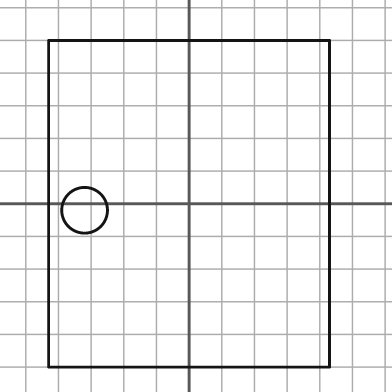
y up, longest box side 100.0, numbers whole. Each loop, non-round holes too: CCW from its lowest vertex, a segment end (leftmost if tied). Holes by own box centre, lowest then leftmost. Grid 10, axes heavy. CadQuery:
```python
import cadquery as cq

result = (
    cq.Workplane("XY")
    .moveTo(-43.0, -50.0)
    .lineTo(43.0, -50.0)
    .lineTo(43.0, 50.0)
    .lineTo(-43.0, 50.0)
    .close()
    .moveTo(-32.0, -2.0)
    .circle(7.0)
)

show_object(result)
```